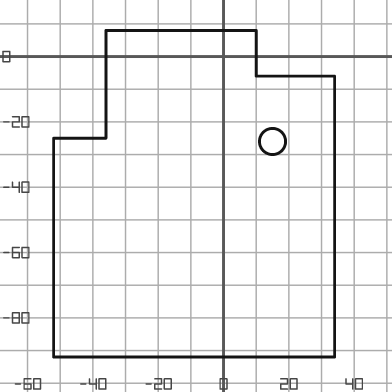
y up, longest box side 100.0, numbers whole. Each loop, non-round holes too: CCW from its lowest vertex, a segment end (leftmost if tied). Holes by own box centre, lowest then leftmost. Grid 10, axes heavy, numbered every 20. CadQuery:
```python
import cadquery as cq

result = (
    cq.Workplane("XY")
    .moveTo(-52.0, -92.0)
    .lineTo(34.0, -92.0)
    .lineTo(34.0, -6.0)
    .lineTo(10.0, -6.0)
    .lineTo(10.0, 8.0)
    .lineTo(-36.0, 8.0)
    .lineTo(-36.0, -25.0)
    .lineTo(-52.0, -25.0)
    .close()
    .moveTo(15.0, -26.0)
    .circle(4.0)
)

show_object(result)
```